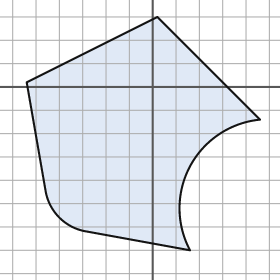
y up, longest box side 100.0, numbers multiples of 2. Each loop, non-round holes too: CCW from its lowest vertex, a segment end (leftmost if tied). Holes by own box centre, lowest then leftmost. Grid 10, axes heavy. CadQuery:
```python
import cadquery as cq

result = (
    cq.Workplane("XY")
    .moveTo(16.0, -70.0)
    .threePointArc((16.0, -34.0), (46.0, -14.0))
    .lineTo(2.0, 30.0)
    .lineTo(-54.0, 2.0)
    .lineTo(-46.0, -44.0)
    .threePointArc((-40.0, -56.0), (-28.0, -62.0))
    .close()
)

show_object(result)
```